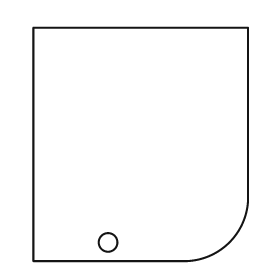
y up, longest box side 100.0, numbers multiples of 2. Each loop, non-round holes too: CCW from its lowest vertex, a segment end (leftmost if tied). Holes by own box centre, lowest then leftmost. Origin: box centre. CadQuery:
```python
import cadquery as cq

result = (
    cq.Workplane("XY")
    .moveTo(-46.0, -50.0)
    .lineTo(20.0, -50.0)
    .threePointArc((38.0, -42.0), (46.0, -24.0))
    .lineTo(46.0, 50.0)
    .lineTo(-46.0, 50.0)
    .close()
    .moveTo(-14.0, -42.0)
    .circle(4.0)
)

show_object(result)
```